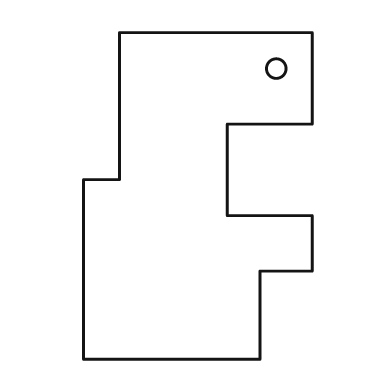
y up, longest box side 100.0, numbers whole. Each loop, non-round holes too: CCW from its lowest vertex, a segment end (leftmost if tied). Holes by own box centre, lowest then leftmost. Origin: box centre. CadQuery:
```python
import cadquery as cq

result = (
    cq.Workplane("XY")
    .moveTo(-35.0, -50.0)
    .lineTo(19.0, -50.0)
    .lineTo(19.0, -23.0)
    .lineTo(35.0, -23.0)
    .lineTo(35.0, -6.0)
    .lineTo(9.0, -6.0)
    .lineTo(9.0, 22.0)
    .lineTo(35.0, 22.0)
    .lineTo(35.0, 50.0)
    .lineTo(-24.0, 50.0)
    .lineTo(-24.0, 5.0)
    .lineTo(-35.0, 5.0)
    .close()
    .moveTo(24.0, 39.0)
    .circle(3.0)
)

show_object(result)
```